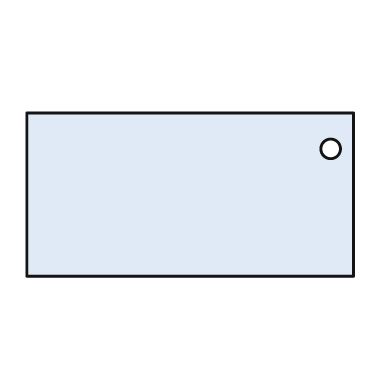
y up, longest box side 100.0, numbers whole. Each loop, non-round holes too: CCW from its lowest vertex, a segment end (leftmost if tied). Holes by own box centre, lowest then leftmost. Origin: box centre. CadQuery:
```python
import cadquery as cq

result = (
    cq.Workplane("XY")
    .moveTo(-50.0, -25.0)
    .lineTo(50.0, -25.0)
    .lineTo(50.0, 25.0)
    .lineTo(-50.0, 25.0)
    .close()
    .moveTo(43.0, 14.0)
    .circle(3.0)
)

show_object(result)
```